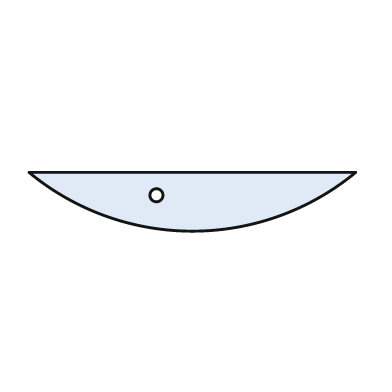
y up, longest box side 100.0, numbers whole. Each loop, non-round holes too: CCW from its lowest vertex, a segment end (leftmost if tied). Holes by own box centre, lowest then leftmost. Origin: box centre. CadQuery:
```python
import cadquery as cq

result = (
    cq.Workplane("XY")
    .moveTo(-50.0, 9.0)
    .threePointArc((0.0, -9.0), (50.0, 9.0))
    .close()
    .moveTo(-11.0, 2.0)
    .circle(2.0)
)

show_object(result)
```